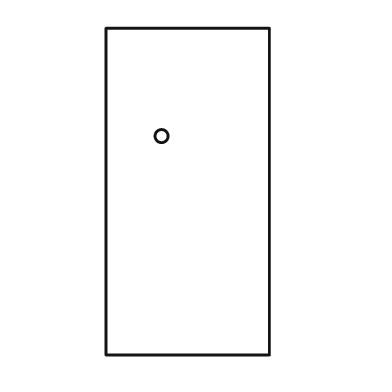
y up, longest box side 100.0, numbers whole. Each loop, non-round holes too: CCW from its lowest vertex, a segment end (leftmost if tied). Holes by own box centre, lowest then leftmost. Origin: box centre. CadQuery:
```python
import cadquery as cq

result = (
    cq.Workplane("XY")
    .moveTo(-25.0, -50.0)
    .lineTo(25.0, -50.0)
    .lineTo(25.0, 50.0)
    .lineTo(-25.0, 50.0)
    .close()
    .moveTo(-8.0, 17.0)
    .circle(2.0)
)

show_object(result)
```